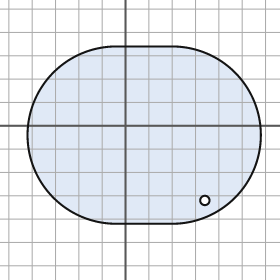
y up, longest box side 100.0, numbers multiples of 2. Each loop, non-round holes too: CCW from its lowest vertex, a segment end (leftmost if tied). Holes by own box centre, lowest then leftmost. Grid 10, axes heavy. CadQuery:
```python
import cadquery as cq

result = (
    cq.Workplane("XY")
    .moveTo(-4.0, -42.0)
    .lineTo(20.0, -42.0)
    .threePointArc((58.0, -4.0), (20.0, 34.0))
    .lineTo(-4.0, 34.0)
    .threePointArc((-42.0, -4.0), (-4.0, -42.0))
    .close()
    .moveTo(34.0, -32.0)
    .circle(2.0)
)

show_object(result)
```